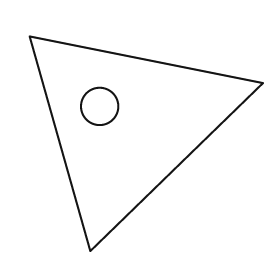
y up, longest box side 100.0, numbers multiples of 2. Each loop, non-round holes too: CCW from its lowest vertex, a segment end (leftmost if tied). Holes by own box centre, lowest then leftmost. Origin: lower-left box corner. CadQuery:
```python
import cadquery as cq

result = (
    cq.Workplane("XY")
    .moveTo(26.0, 0.0)
    .lineTo(100.0, 72.0)
    .lineTo(0.0, 92.0)
    .close()
    .moveTo(30.0, 62.0)
    .circle(8.0)
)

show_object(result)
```